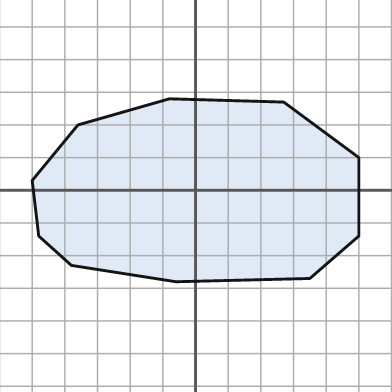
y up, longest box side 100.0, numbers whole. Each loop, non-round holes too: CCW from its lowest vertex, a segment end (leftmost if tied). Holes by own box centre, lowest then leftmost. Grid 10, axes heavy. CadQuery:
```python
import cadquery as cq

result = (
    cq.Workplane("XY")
    .moveTo(-6.0, -28.0)
    .lineTo(35.0, -27.0)
    .lineTo(50.0, -14.0)
    .lineTo(50.0, 10.0)
    .lineTo(27.0, 27.0)
    .lineTo(-8.0, 28.0)
    .lineTo(-36.0, 20.0)
    .lineTo(-50.0, 3.0)
    .lineTo(-48.0, -14.0)
    .lineTo(-38.0, -23.0)
    .close()
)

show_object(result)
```